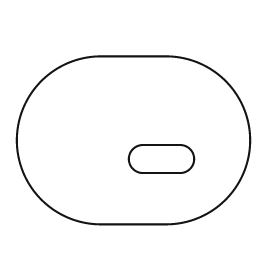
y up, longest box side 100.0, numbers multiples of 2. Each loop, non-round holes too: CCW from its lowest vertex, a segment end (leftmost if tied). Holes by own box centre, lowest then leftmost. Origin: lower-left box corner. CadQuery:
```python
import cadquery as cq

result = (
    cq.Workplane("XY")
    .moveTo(36.0, 0.0)
    .lineTo(64.0, 0.0)
    .threePointArc((100.0, 36.0), (64.0, 72.0))
    .lineTo(36.0, 72.0)
    .threePointArc((0.0, 36.0), (36.0, 0.0))
    .close()
    .moveTo(54.0, 22.0)
    .lineTo(70.0, 22.0)
    .threePointArc((76.0, 28.0), (70.0, 34.0))
    .lineTo(54.0, 34.0)
    .threePointArc((48.0, 28.0), (54.0, 22.0))
    .close()
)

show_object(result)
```